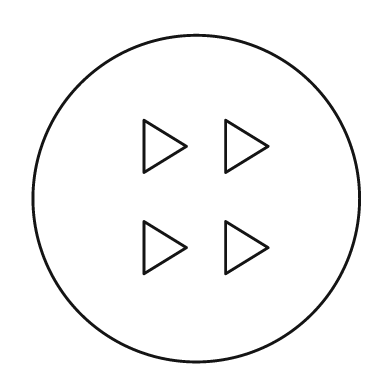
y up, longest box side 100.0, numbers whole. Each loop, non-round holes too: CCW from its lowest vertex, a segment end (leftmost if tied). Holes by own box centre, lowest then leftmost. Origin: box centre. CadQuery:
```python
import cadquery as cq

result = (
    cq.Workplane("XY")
    .moveTo(0.0, 0.0)
    .circle(50.0)
    .moveTo(-16.0, -23.0)
    .lineTo(-3.0, -15.0)
    .lineTo(-16.0, -7.0)
    .close()
    .moveTo(9.0, -23.0)
    .lineTo(22.0, -15.0)
    .lineTo(9.0, -7.0)
    .close()
    .moveTo(-16.0, 8.0)
    .lineTo(-3.0, 16.0)
    .lineTo(-16.0, 24.0)
    .close()
    .moveTo(9.0, 8.0)
    .lineTo(22.0, 16.0)
    .lineTo(9.0, 24.0)
    .close()
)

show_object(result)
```